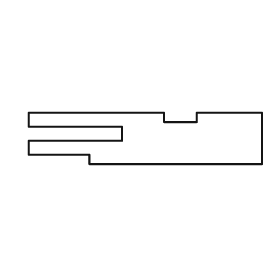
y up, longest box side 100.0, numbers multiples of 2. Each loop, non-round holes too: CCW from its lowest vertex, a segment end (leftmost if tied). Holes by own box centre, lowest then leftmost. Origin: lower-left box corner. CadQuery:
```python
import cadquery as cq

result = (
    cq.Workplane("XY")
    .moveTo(26.0, 0.0)
    .lineTo(100.0, 0.0)
    .lineTo(100.0, 22.0)
    .lineTo(72.0, 22.0)
    .lineTo(72.0, 18.0)
    .lineTo(58.0, 18.0)
    .lineTo(58.0, 22.0)
    .lineTo(0.0, 22.0)
    .lineTo(0.0, 16.0)
    .lineTo(40.0, 16.0)
    .lineTo(40.0, 10.0)
    .lineTo(0.0, 10.0)
    .lineTo(0.0, 4.0)
    .lineTo(26.0, 4.0)
    .close()
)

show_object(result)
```